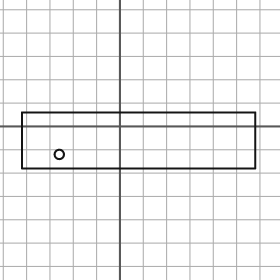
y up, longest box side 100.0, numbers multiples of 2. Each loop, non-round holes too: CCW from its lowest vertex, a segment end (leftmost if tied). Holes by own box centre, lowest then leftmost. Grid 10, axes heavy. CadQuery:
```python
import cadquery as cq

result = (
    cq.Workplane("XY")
    .moveTo(-42.0, -18.0)
    .lineTo(58.0, -18.0)
    .lineTo(58.0, 6.0)
    .lineTo(-42.0, 6.0)
    .close()
    .moveTo(-26.0, -12.0)
    .circle(2.0)
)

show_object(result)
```